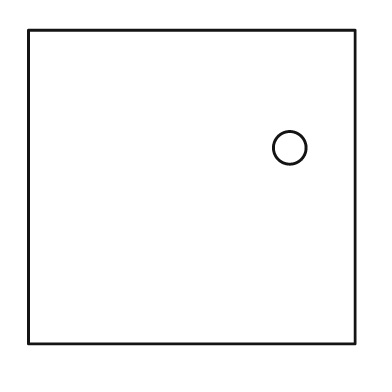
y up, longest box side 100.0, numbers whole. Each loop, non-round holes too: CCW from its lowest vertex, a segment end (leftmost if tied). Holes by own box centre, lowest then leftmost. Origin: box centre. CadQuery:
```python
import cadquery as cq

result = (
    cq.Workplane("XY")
    .moveTo(-50.0, -48.0)
    .lineTo(50.0, -48.0)
    .lineTo(50.0, 48.0)
    .lineTo(-50.0, 48.0)
    .close()
    .moveTo(30.0, 12.0)
    .circle(5.0)
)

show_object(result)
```